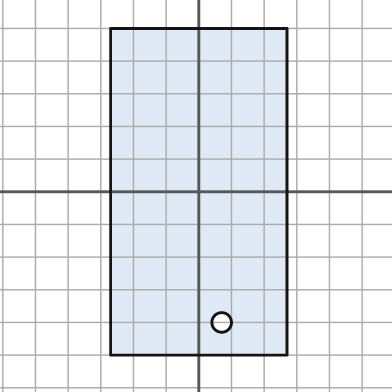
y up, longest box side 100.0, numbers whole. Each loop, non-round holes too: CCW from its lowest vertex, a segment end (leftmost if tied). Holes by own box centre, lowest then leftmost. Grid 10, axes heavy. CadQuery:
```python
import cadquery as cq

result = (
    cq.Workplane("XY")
    .moveTo(-27.0, -50.0)
    .lineTo(27.0, -50.0)
    .lineTo(27.0, 50.0)
    .lineTo(-27.0, 50.0)
    .close()
    .moveTo(7.0, -40.0)
    .circle(3.0)
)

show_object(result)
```